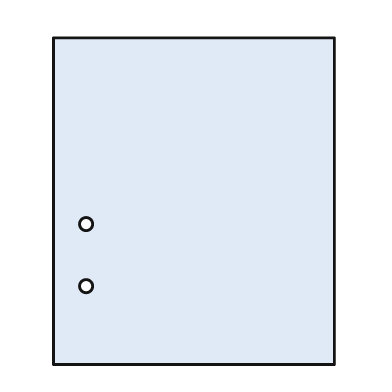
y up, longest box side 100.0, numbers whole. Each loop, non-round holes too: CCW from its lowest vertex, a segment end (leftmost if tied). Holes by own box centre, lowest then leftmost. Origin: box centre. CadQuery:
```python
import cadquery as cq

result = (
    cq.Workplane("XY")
    .moveTo(-43.0, -50.0)
    .lineTo(43.0, -50.0)
    .lineTo(43.0, 50.0)
    .lineTo(-43.0, 50.0)
    .close()
    .moveTo(-33.0, -26.0)
    .circle(2.0)
    .moveTo(-33.0, -7.0)
    .circle(2.0)
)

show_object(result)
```